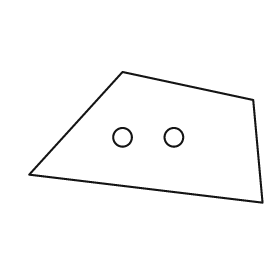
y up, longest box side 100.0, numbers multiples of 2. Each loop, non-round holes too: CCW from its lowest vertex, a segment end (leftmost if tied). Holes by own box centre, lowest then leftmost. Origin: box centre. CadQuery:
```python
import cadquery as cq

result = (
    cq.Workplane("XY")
    .moveTo(50.0, -28.0)
    .lineTo(46.0, 16.0)
    .lineTo(-10.0, 28.0)
    .lineTo(-50.0, -16.0)
    .close()
    .moveTo(-10.0, 0.0)
    .circle(4.0)
    .moveTo(12.0, 0.0)
    .circle(4.0)
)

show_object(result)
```